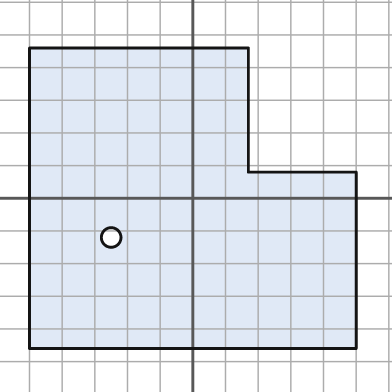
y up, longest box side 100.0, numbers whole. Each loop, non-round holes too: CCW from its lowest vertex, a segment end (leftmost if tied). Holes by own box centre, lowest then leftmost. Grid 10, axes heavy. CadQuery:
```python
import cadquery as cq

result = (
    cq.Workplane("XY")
    .moveTo(-50.0, -46.0)
    .lineTo(50.0, -46.0)
    .lineTo(50.0, 8.0)
    .lineTo(17.0, 8.0)
    .lineTo(17.0, 46.0)
    .lineTo(-50.0, 46.0)
    .close()
    .moveTo(-25.0, -12.0)
    .circle(3.0)
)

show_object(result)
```